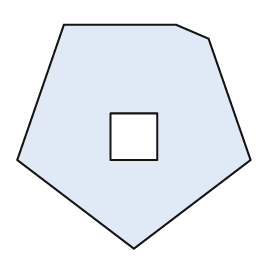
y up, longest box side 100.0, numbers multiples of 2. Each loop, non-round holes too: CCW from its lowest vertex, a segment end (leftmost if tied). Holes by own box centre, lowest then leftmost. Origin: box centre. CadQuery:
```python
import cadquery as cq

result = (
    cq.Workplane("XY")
    .moveTo(0.0, -48.0)
    .lineTo(50.0, -10.0)
    .lineTo(32.0, 42.0)
    .lineTo(18.0, 48.0)
    .lineTo(-30.0, 48.0)
    .lineTo(-50.0, -10.0)
    .close()
    .moveTo(-10.0, -10.0)
    .lineTo(10.0, -10.0)
    .lineTo(10.0, 10.0)
    .lineTo(-10.0, 10.0)
    .close()
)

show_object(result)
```